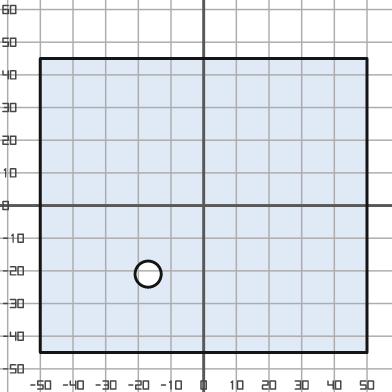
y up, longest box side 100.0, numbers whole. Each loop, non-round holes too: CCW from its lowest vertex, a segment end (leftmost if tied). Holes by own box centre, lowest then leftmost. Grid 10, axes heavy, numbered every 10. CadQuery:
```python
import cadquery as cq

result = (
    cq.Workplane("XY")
    .moveTo(-50.0, -45.0)
    .lineTo(50.0, -45.0)
    .lineTo(50.0, 45.0)
    .lineTo(-50.0, 45.0)
    .close()
    .moveTo(-17.0, -21.0)
    .circle(4.0)
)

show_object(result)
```